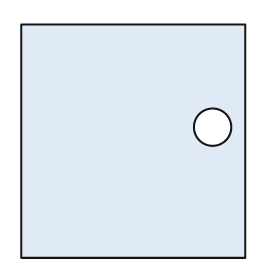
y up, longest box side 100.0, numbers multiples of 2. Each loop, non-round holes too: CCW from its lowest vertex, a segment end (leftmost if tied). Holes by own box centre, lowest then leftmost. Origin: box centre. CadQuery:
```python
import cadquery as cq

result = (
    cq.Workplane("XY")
    .moveTo(-48.0, -50.0)
    .lineTo(48.0, -50.0)
    .lineTo(48.0, 50.0)
    .lineTo(-48.0, 50.0)
    .close()
    .moveTo(34.0, 6.0)
    .circle(8.0)
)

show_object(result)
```